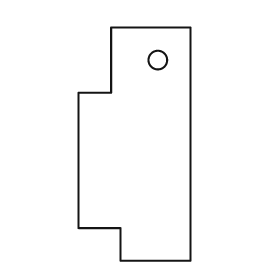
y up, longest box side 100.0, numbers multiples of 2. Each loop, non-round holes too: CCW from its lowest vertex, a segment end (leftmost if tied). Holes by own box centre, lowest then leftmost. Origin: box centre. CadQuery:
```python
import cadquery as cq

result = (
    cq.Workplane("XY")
    .moveTo(-6.0, -50.0)
    .lineTo(24.0, -50.0)
    .lineTo(24.0, 50.0)
    .lineTo(-10.0, 50.0)
    .lineTo(-10.0, 22.0)
    .lineTo(-24.0, 22.0)
    .lineTo(-24.0, -36.0)
    .lineTo(-6.0, -36.0)
    .close()
    .moveTo(10.0, 36.0)
    .circle(4.0)
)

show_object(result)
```